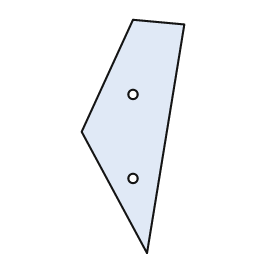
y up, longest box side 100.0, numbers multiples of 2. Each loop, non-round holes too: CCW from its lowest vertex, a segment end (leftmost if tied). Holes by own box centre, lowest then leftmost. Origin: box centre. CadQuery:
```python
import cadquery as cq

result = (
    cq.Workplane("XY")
    .moveTo(6.0, -50.0)
    .lineTo(22.0, 48.0)
    .lineTo(0.0, 50.0)
    .lineTo(-22.0, 2.0)
    .close()
    .moveTo(0.0, -18.0)
    .circle(2.0)
    .moveTo(0.0, 18.0)
    .circle(2.0)
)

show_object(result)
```